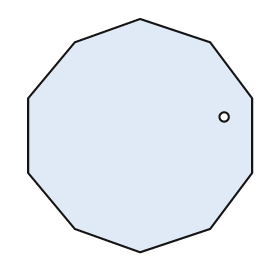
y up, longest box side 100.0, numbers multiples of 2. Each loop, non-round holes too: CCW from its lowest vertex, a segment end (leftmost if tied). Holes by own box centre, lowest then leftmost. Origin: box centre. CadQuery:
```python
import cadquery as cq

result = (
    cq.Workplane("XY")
    .moveTo(0.0, -50.0)
    .lineTo(30.0, -40.0)
    .lineTo(48.0, -16.0)
    .lineTo(48.0, 16.0)
    .lineTo(30.0, 40.0)
    .lineTo(0.0, 50.0)
    .lineTo(-28.0, 40.0)
    .lineTo(-48.0, 16.0)
    .lineTo(-48.0, -16.0)
    .lineTo(-28.0, -40.0)
    .close()
    .moveTo(36.0, 8.0)
    .circle(2.0)
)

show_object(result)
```